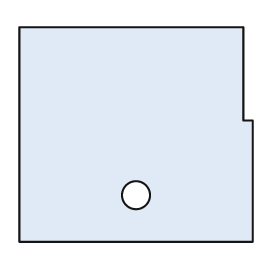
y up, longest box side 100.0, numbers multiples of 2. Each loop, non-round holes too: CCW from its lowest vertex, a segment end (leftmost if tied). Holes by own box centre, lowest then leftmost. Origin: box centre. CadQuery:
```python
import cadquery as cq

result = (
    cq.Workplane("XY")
    .moveTo(-50.0, -46.0)
    .lineTo(50.0, -46.0)
    .lineTo(50.0, 6.0)
    .lineTo(46.0, 6.0)
    .lineTo(46.0, 46.0)
    .lineTo(-50.0, 46.0)
    .close()
    .moveTo(0.0, -26.0)
    .circle(6.0)
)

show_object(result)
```